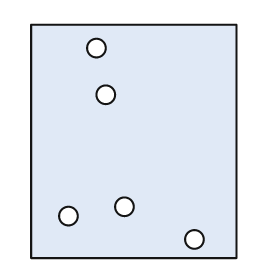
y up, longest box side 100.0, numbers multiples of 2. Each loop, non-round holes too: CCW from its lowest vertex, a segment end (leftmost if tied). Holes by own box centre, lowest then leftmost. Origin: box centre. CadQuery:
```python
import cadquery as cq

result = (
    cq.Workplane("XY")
    .moveTo(-44.0, -50.0)
    .lineTo(44.0, -50.0)
    .lineTo(44.0, 50.0)
    .lineTo(-44.0, 50.0)
    .close()
    .moveTo(26.0, -42.0)
    .circle(4.0)
    .moveTo(-28.0, -32.0)
    .circle(4.0)
    .moveTo(-4.0, -28.0)
    .circle(4.0)
    .moveTo(-12.0, 20.0)
    .circle(4.0)
    .moveTo(-16.0, 40.0)
    .circle(4.0)
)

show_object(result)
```